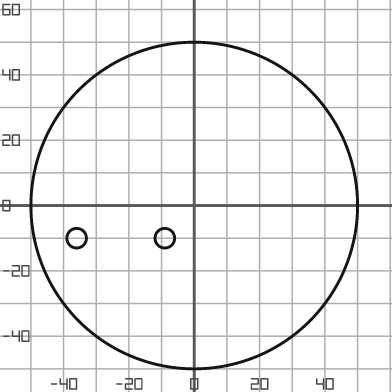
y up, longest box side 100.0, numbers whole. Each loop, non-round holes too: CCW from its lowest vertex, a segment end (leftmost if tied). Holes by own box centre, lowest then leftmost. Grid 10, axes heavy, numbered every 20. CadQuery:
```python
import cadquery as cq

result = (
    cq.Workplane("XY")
    .moveTo(0.0, 0.0)
    .circle(50.0)
    .moveTo(-36.0, -10.0)
    .circle(3.0)
    .moveTo(-9.0, -10.0)
    .circle(3.0)
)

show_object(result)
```